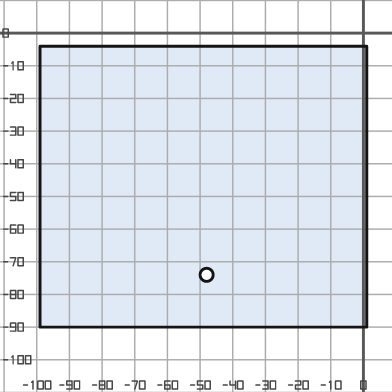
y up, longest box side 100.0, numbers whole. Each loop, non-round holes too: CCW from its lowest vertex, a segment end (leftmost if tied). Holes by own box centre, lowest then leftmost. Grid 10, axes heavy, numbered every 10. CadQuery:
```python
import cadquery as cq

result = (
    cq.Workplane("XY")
    .moveTo(-99.0, -90.0)
    .lineTo(1.0, -90.0)
    .lineTo(1.0, -4.0)
    .lineTo(-99.0, -4.0)
    .close()
    .moveTo(-48.0, -74.0)
    .circle(2.0)
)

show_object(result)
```